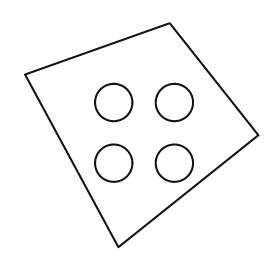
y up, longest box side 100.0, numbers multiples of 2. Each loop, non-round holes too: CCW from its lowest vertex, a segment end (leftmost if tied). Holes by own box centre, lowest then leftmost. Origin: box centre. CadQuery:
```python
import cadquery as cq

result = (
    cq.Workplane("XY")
    .moveTo(-10.0, -48.0)
    .lineTo(50.0, 0.0)
    .lineTo(12.0, 48.0)
    .lineTo(-50.0, 26.0)
    .close()
    .moveTo(-12.0, -12.0)
    .circle(8.0)
    .moveTo(14.0, -12.0)
    .circle(8.0)
    .moveTo(-12.0, 14.0)
    .circle(8.0)
    .moveTo(14.0, 14.0)
    .circle(8.0)
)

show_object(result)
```